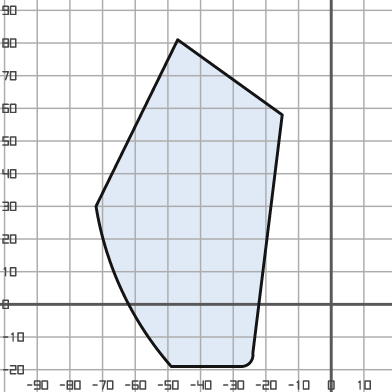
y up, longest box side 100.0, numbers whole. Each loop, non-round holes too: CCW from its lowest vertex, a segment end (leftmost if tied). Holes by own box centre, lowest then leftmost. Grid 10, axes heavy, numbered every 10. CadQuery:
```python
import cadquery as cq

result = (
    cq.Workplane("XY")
    .moveTo(-49.0, -19.0)
    .lineTo(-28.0, -19.0)
    .threePointArc((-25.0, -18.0), (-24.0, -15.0))
    .lineTo(-15.0, 58.0)
    .lineTo(-47.0, 81.0)
    .lineTo(-72.0, 30.0)
    .threePointArc((-64.0, 4.0), (-49.0, -19.0))
    .close()
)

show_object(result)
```